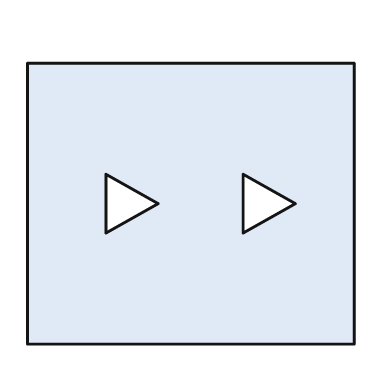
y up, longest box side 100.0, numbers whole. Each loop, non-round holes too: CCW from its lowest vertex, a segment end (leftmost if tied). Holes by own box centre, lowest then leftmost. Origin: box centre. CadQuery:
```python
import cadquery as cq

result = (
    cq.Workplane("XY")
    .moveTo(-50.0, -43.0)
    .lineTo(50.0, -43.0)
    .lineTo(50.0, 43.0)
    .lineTo(-50.0, 43.0)
    .close()
    .moveTo(-26.0, -9.0)
    .lineTo(-10.0, 0.0)
    .lineTo(-26.0, 9.0)
    .close()
    .moveTo(16.0, -9.0)
    .lineTo(32.0, 0.0)
    .lineTo(16.0, 9.0)
    .close()
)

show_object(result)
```